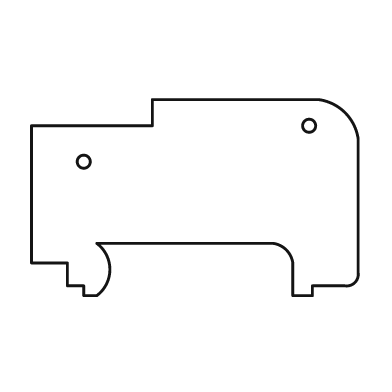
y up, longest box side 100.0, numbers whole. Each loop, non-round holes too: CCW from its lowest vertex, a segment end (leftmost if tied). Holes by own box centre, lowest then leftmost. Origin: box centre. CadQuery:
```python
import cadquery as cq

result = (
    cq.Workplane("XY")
    .moveTo(-34.0, -30.0)
    .lineTo(-30.0, -30.0)
    .threePointArc((-26.0, -22.0), (-30.0, -14.0))
    .lineTo(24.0, -14.0)
    .threePointArc((28.0, -16.0), (30.0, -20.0))
    .lineTo(30.0, -30.0)
    .lineTo(36.0, -30.0)
    .lineTo(36.0, -27.0)
    .lineTo(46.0, -27.0)
    .threePointArc((49.0, -26.0), (50.0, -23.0))
    .lineTo(50.0, 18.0)
    .threePointArc((46.0, 26.0), (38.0, 30.0))
    .lineTo(-13.0, 30.0)
    .lineTo(-13.0, 22.0)
    .lineTo(-50.0, 22.0)
    .lineTo(-50.0, -20.0)
    .lineTo(-39.0, -20.0)
    .lineTo(-39.0, -27.0)
    .lineTo(-34.0, -27.0)
    .close()
    .moveTo(-34.0, 11.0)
    .circle(2.0)
    .moveTo(35.0, 22.0)
    .circle(2.0)
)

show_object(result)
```